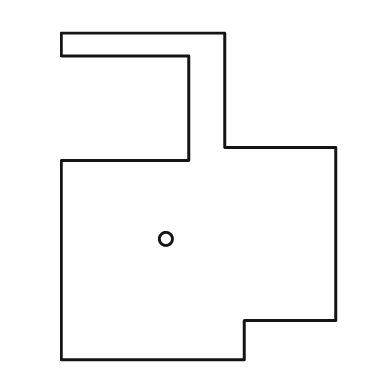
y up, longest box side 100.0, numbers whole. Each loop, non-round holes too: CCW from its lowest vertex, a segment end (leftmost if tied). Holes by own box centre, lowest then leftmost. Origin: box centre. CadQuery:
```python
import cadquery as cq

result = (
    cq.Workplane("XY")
    .moveTo(-42.0, -50.0)
    .lineTo(14.0, -50.0)
    .lineTo(14.0, -38.0)
    .lineTo(42.0, -38.0)
    .lineTo(42.0, 15.0)
    .lineTo(8.0, 15.0)
    .lineTo(8.0, 50.0)
    .lineTo(-42.0, 50.0)
    .lineTo(-42.0, 43.0)
    .lineTo(-3.0, 43.0)
    .lineTo(-3.0, 11.0)
    .lineTo(-42.0, 11.0)
    .close()
    .moveTo(-10.0, -13.0)
    .circle(2.0)
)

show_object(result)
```